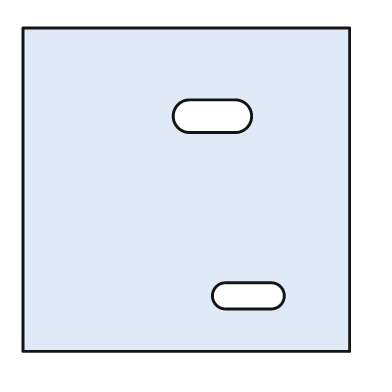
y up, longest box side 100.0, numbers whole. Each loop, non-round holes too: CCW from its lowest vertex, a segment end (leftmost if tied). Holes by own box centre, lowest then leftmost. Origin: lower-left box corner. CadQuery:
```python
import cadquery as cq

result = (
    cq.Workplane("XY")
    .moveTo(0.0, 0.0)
    .lineTo(100.0, 0.0)
    .lineTo(100.0, 99.0)
    .lineTo(0.0, 99.0)
    .close()
    .moveTo(62.0, 13.0)
    .lineTo(76.0, 13.0)
    .threePointArc((80.0, 17.0), (76.0, 21.0))
    .lineTo(62.0, 21.0)
    .threePointArc((58.0, 17.0), (62.0, 13.0))
    .close()
    .moveTo(51.0, 67.0)
    .lineTo(65.0, 67.0)
    .threePointArc((70.0, 72.0), (65.0, 77.0))
    .lineTo(51.0, 77.0)
    .threePointArc((46.0, 72.0), (51.0, 67.0))
    .close()
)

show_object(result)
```